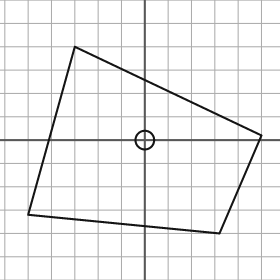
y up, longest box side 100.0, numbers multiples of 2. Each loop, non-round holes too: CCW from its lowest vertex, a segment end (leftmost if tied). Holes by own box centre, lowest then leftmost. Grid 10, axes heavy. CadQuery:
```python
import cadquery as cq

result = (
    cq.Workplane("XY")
    .moveTo(32.0, -40.0)
    .lineTo(50.0, 2.0)
    .lineTo(-30.0, 40.0)
    .lineTo(-50.0, -32.0)
    .close()
    .moveTo(0.0, 0.0)
    .circle(4.0)
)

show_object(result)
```